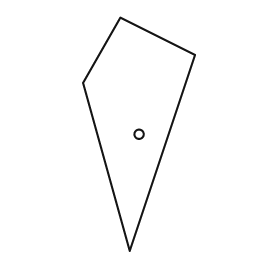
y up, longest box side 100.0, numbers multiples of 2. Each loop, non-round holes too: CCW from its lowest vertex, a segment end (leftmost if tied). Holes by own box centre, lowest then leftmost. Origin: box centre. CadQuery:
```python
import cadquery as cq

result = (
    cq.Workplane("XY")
    .moveTo(-4.0, -50.0)
    .lineTo(24.0, 34.0)
    .lineTo(-8.0, 50.0)
    .lineTo(-24.0, 22.0)
    .close()
    .moveTo(0.0, 0.0)
    .circle(2.0)
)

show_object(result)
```